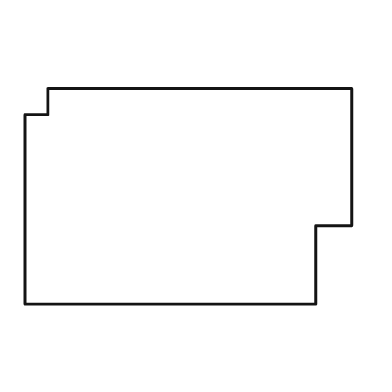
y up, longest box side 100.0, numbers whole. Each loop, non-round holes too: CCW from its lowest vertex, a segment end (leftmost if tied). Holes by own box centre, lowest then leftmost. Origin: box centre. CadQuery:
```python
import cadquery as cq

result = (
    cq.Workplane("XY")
    .moveTo(-50.0, -33.0)
    .lineTo(39.0, -33.0)
    .lineTo(39.0, -9.0)
    .lineTo(50.0, -9.0)
    .lineTo(50.0, 33.0)
    .lineTo(-43.0, 33.0)
    .lineTo(-43.0, 25.0)
    .lineTo(-50.0, 25.0)
    .close()
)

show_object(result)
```